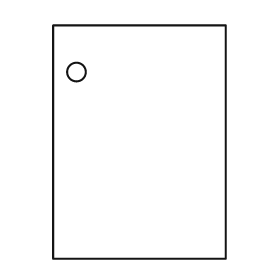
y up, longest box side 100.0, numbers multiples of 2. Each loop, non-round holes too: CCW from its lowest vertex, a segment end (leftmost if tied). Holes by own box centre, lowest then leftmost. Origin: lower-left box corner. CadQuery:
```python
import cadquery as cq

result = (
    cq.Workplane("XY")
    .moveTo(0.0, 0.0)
    .lineTo(74.0, 0.0)
    .lineTo(74.0, 100.0)
    .lineTo(0.0, 100.0)
    .close()
    .moveTo(10.0, 80.0)
    .circle(4.0)
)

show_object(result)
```